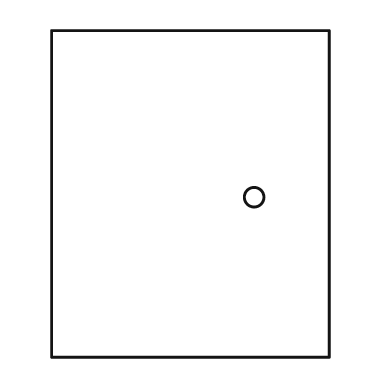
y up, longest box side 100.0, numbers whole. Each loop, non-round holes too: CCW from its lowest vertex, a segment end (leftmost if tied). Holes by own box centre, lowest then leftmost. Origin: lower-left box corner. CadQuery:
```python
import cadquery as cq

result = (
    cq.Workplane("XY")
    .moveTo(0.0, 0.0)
    .lineTo(85.0, 0.0)
    .lineTo(85.0, 100.0)
    .lineTo(0.0, 100.0)
    .close()
    .moveTo(62.0, 49.0)
    .circle(3.0)
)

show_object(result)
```